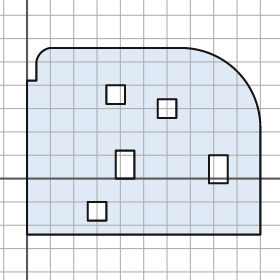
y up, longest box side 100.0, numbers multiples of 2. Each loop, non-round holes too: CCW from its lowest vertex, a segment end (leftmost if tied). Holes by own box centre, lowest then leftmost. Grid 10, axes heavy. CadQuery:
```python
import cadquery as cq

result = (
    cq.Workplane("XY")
    .moveTo(0.0, -24.0)
    .lineTo(100.0, -24.0)
    .lineTo(100.0, 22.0)
    .threePointArc((90.0, 46.0), (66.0, 56.0))
    .lineTo(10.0, 56.0)
    .threePointArc((6.0, 54.0), (4.0, 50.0))
    .lineTo(4.0, 42.0)
    .lineTo(0.0, 42.0)
    .close()
    .moveTo(26.0, -18.0)
    .lineTo(34.0, -18.0)
    .lineTo(34.0, -10.0)
    .lineTo(26.0, -10.0)
    .close()
    .moveTo(78.0, -2.0)
    .lineTo(86.0, -2.0)
    .lineTo(86.0, 10.0)
    .lineTo(78.0, 10.0)
    .close()
    .moveTo(38.0, 0.0)
    .lineTo(46.0, 0.0)
    .lineTo(46.0, 12.0)
    .lineTo(38.0, 12.0)
    .close()
    .moveTo(56.0, 26.0)
    .lineTo(64.0, 26.0)
    .lineTo(64.0, 34.0)
    .lineTo(56.0, 34.0)
    .close()
    .moveTo(34.0, 32.0)
    .lineTo(42.0, 32.0)
    .lineTo(42.0, 40.0)
    .lineTo(34.0, 40.0)
    .close()
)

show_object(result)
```